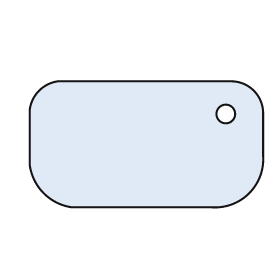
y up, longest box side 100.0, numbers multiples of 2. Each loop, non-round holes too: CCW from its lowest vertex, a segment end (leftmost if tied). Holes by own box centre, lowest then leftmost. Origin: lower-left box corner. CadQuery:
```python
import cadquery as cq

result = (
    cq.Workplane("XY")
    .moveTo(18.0, 0.0)
    .lineTo(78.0, 0.0)
    .threePointArc((94.0, 6.0), (100.0, 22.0))
    .lineTo(100.0, 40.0)
    .threePointArc((96.0, 50.0), (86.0, 54.0))
    .lineTo(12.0, 54.0)
    .threePointArc((4.0, 50.0), (0.0, 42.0))
    .lineTo(0.0, 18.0)
    .threePointArc((6.0, 6.0), (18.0, 0.0))
    .close()
    .moveTo(84.0, 40.0)
    .circle(4.0)
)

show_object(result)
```